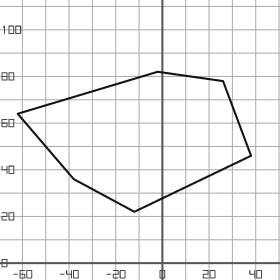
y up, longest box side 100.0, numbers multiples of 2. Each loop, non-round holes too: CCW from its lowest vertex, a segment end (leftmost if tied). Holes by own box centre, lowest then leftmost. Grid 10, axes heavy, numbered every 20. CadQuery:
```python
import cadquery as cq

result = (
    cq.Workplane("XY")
    .moveTo(-12.0, 22.0)
    .lineTo(38.0, 46.0)
    .lineTo(26.0, 78.0)
    .lineTo(-2.0, 82.0)
    .lineTo(-62.0, 64.0)
    .lineTo(-38.0, 36.0)
    .close()
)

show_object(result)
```